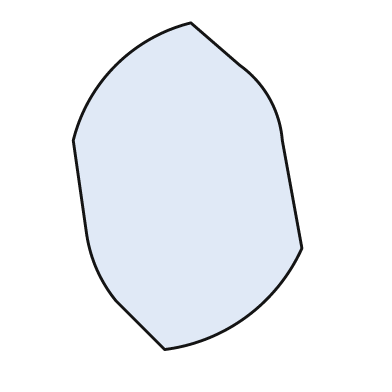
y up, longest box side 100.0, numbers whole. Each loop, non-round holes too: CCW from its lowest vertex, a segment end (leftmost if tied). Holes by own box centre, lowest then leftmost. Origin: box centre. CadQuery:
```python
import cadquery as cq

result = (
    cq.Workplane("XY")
    .moveTo(-7.0, -50.0)
    .threePointArc((18.0, -40.0), (35.0, -19.0))
    .lineTo(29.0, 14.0)
    .threePointArc((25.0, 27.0), (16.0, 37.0))
    .lineTo(1.0, 50.0)
    .threePointArc((-22.0, 37.0), (-35.0, 14.0))
    .lineTo(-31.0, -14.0)
    .threePointArc((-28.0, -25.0), (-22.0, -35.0))
    .close()
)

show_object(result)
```